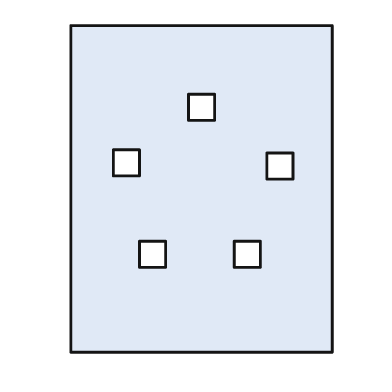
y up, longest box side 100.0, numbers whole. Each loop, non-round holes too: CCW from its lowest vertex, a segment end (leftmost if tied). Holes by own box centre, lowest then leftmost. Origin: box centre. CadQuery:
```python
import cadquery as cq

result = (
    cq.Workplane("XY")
    .moveTo(-40.0, -50.0)
    .lineTo(40.0, -50.0)
    .lineTo(40.0, 50.0)
    .lineTo(-40.0, 50.0)
    .close()
    .moveTo(-19.0, -24.0)
    .lineTo(-11.0, -24.0)
    .lineTo(-11.0, -16.0)
    .lineTo(-19.0, -16.0)
    .close()
    .moveTo(10.0, -24.0)
    .lineTo(18.0, -24.0)
    .lineTo(18.0, -16.0)
    .lineTo(10.0, -16.0)
    .close()
    .moveTo(20.0, 3.0)
    .lineTo(28.0, 3.0)
    .lineTo(28.0, 11.0)
    .lineTo(20.0, 11.0)
    .close()
    .moveTo(-27.0, 4.0)
    .lineTo(-19.0, 4.0)
    .lineTo(-19.0, 12.0)
    .lineTo(-27.0, 12.0)
    .close()
    .moveTo(-4.0, 21.0)
    .lineTo(4.0, 21.0)
    .lineTo(4.0, 29.0)
    .lineTo(-4.0, 29.0)
    .close()
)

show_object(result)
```